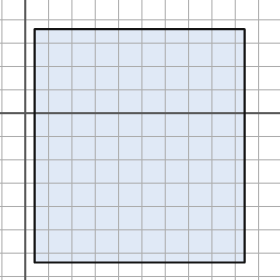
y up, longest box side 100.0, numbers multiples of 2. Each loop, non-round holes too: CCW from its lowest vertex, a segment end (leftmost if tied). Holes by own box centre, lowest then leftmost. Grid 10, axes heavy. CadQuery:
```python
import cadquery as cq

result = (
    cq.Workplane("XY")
    .moveTo(4.0, -64.0)
    .lineTo(94.0, -64.0)
    .lineTo(94.0, 36.0)
    .lineTo(4.0, 36.0)
    .close()
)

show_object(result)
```